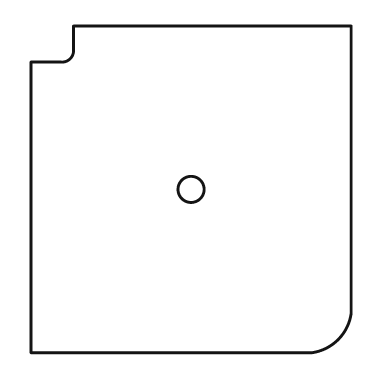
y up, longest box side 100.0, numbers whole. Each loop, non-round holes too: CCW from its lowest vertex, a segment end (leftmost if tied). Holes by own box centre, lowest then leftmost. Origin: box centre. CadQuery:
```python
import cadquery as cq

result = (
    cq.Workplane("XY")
    .moveTo(-49.0, -50.0)
    .lineTo(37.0, -50.0)
    .threePointArc((45.0, -46.0), (49.0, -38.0))
    .lineTo(49.0, 50.0)
    .lineTo(-36.0, 50.0)
    .lineTo(-36.0, 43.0)
    .threePointArc((-37.0, 40.0), (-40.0, 39.0))
    .lineTo(-49.0, 39.0)
    .close()
    .moveTo(0.0, 0.0)
    .circle(4.0)
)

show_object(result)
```